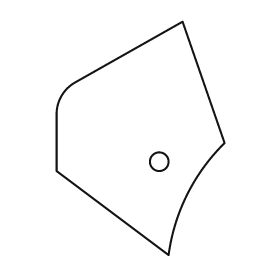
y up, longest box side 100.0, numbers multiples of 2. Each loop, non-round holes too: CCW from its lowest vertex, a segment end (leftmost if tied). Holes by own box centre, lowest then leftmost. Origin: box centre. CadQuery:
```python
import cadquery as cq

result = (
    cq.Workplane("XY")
    .moveTo(12.0, -50.0)
    .threePointArc((20.0, -24.0), (36.0, -2.0))
    .lineTo(18.0, 50.0)
    .lineTo(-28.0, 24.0)
    .threePointArc((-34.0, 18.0), (-36.0, 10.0))
    .lineTo(-36.0, -14.0)
    .close()
    .moveTo(8.0, -10.0)
    .circle(4.0)
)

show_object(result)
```